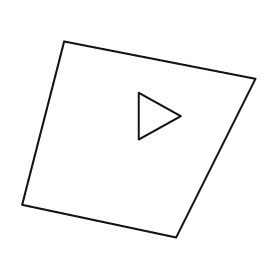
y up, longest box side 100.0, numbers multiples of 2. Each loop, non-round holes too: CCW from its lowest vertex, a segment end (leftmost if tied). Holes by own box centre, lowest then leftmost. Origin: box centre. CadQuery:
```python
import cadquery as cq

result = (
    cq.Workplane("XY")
    .moveTo(16.0, -42.0)
    .lineTo(50.0, 26.0)
    .lineTo(-32.0, 42.0)
    .lineTo(-50.0, -28.0)
    .close()
    .moveTo(0.0, 0.0)
    .lineTo(18.0, 10.0)
    .lineTo(0.0, 20.0)
    .close()
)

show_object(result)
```